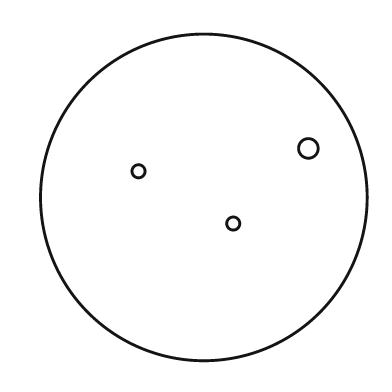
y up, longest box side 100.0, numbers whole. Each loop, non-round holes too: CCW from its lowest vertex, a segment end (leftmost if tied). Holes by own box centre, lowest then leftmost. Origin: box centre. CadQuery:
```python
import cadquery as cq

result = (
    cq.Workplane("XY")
    .moveTo(0.0, 0.0)
    .circle(50.0)
    .moveTo(9.0, -8.0)
    .circle(2.0)
    .moveTo(-20.0, 8.0)
    .circle(2.0)
    .moveTo(32.0, 15.0)
    .circle(3.0)
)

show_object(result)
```